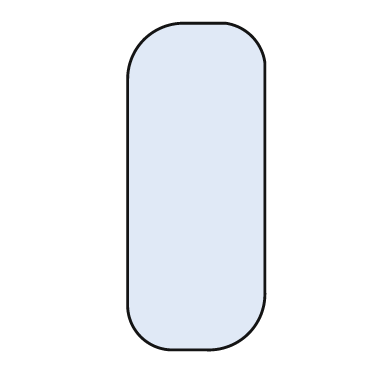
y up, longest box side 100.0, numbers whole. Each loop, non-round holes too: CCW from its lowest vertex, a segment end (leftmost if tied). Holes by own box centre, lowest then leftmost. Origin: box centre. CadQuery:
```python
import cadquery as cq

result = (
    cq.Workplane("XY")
    .moveTo(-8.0, -50.0)
    .lineTo(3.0, -50.0)
    .threePointArc((16.0, -45.0), (21.0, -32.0))
    .lineTo(21.0, 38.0)
    .threePointArc((17.0, 46.0), (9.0, 50.0))
    .lineTo(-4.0, 50.0)
    .threePointArc((-16.0, 45.0), (-21.0, 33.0))
    .lineTo(-21.0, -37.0)
    .threePointArc((-17.0, -46.0), (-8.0, -50.0))
    .close()
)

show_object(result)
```